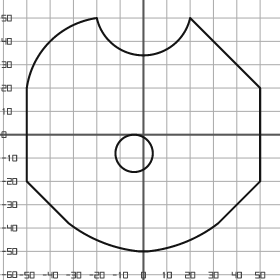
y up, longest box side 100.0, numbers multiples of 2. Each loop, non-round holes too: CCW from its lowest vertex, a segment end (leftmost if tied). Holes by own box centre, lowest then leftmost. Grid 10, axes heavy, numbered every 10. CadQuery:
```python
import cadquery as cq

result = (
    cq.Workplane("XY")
    .moveTo(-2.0, -50.0)
    .lineTo(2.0, -50.0)
    .threePointArc((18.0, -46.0), (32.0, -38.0))
    .lineTo(50.0, -20.0)
    .lineTo(50.0, 20.0)
    .lineTo(20.0, 50.0)
    .threePointArc((0.0, 34.0), (-20.0, 50.0))
    .threePointArc((-40.0, 40.0), (-50.0, 20.0))
    .lineTo(-50.0, -20.0)
    .lineTo(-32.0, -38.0)
    .threePointArc((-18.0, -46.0), (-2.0, -50.0))
    .close()
    .moveTo(-4.0, -8.0)
    .circle(8.0)
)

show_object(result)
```